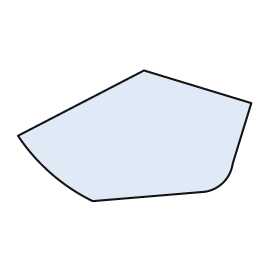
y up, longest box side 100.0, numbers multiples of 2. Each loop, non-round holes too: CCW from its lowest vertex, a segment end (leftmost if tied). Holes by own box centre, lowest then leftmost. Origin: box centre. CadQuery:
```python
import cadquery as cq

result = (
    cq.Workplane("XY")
    .moveTo(-18.0, -28.0)
    .lineTo(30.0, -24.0)
    .threePointArc((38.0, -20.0), (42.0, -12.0))
    .lineTo(50.0, 14.0)
    .lineTo(4.0, 28.0)
    .lineTo(-50.0, 0.0)
    .threePointArc((-36.0, -16.0), (-18.0, -28.0))
    .close()
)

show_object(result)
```